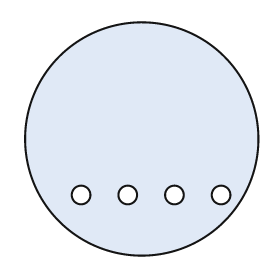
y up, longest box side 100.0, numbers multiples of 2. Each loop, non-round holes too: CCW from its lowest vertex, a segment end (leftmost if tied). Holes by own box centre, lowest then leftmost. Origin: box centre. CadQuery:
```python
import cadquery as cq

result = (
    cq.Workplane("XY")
    .moveTo(0.0, 0.0)
    .circle(50.0)
    .moveTo(-26.0, -24.0)
    .circle(4.0)
    .moveTo(-6.0, -24.0)
    .circle(4.0)
    .moveTo(14.0, -24.0)
    .circle(4.0)
    .moveTo(34.0, -24.0)
    .circle(4.0)
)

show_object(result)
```